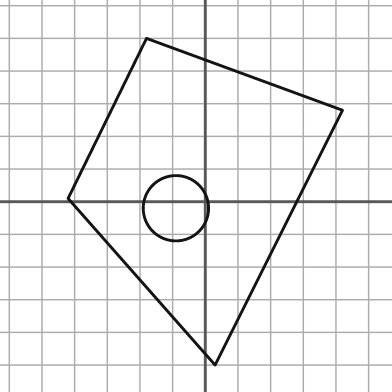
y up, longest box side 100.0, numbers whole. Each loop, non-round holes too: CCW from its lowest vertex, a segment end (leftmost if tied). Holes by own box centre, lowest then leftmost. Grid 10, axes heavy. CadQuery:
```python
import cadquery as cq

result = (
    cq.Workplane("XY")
    .moveTo(3.0, -50.0)
    .lineTo(42.0, 28.0)
    .lineTo(-18.0, 50.0)
    .lineTo(-42.0, 1.0)
    .close()
    .moveTo(-9.0, -2.0)
    .circle(10.0)
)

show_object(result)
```